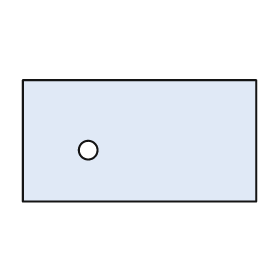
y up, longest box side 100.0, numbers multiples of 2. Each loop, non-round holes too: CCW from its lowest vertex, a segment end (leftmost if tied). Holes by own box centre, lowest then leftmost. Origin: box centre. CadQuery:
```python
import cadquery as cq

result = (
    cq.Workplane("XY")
    .moveTo(-50.0, -26.0)
    .lineTo(50.0, -26.0)
    .lineTo(50.0, 26.0)
    .lineTo(-50.0, 26.0)
    .close()
    .moveTo(-22.0, -4.0)
    .circle(4.0)
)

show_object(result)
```